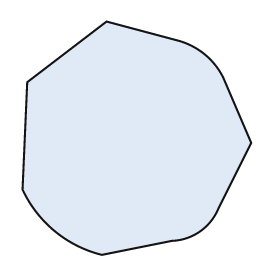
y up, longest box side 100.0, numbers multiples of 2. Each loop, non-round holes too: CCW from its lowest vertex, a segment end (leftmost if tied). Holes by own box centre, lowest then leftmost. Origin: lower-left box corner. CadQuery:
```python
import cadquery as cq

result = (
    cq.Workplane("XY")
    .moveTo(34.0, 0.0)
    .lineTo(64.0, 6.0)
    .threePointArc((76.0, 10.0), (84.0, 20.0))
    .lineTo(98.0, 48.0)
    .lineTo(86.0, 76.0)
    .threePointArc((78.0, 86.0), (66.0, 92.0))
    .lineTo(36.0, 100.0)
    .lineTo(2.0, 74.0)
    .lineTo(0.0, 28.0)
    .threePointArc((14.0, 10.0), (34.0, 0.0))
    .close()
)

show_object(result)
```